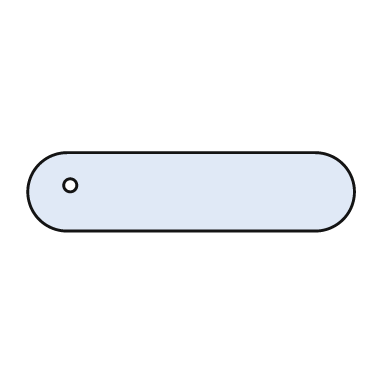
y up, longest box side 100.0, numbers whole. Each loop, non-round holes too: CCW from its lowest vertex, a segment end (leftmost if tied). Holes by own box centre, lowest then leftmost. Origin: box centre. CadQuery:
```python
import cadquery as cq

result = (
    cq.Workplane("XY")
    .moveTo(-38.0, -12.0)
    .lineTo(38.0, -12.0)
    .threePointArc((50.0, 0.0), (38.0, 12.0))
    .lineTo(-38.0, 12.0)
    .threePointArc((-50.0, 0.0), (-38.0, -12.0))
    .close()
    .moveTo(-37.0, 2.0)
    .circle(2.0)
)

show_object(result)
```